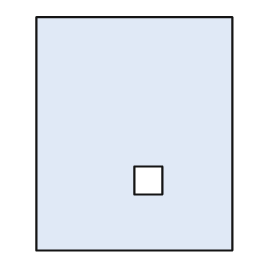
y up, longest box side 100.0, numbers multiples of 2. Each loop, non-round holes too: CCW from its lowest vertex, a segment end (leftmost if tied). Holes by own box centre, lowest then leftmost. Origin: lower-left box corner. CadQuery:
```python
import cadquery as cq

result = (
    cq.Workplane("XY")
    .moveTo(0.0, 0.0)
    .lineTo(84.0, 0.0)
    .lineTo(84.0, 100.0)
    .lineTo(0.0, 100.0)
    .close()
    .moveTo(42.0, 24.0)
    .lineTo(54.0, 24.0)
    .lineTo(54.0, 36.0)
    .lineTo(42.0, 36.0)
    .close()
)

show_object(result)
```